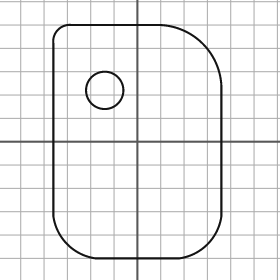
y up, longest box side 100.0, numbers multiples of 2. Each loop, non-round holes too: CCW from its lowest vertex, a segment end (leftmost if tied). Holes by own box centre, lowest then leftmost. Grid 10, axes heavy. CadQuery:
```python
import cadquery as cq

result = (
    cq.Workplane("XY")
    .moveTo(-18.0, -50.0)
    .lineTo(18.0, -50.0)
    .threePointArc((30.0, -44.0), (36.0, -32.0))
    .lineTo(36.0, 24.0)
    .threePointArc((28.0, 42.0), (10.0, 50.0))
    .lineTo(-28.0, 50.0)
    .threePointArc((-34.0, 48.0), (-36.0, 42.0))
    .lineTo(-36.0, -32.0)
    .threePointArc((-30.0, -44.0), (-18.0, -50.0))
    .close()
    .moveTo(-14.0, 22.0)
    .circle(8.0)
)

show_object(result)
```